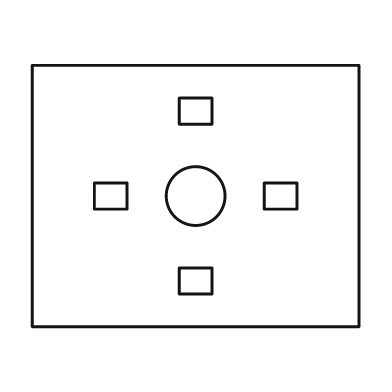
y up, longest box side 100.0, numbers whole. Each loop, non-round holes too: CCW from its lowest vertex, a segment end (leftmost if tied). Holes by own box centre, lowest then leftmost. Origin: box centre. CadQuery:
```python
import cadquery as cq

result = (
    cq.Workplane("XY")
    .moveTo(-50.0, -40.0)
    .lineTo(50.0, -40.0)
    .lineTo(50.0, 40.0)
    .lineTo(-50.0, 40.0)
    .close()
    .moveTo(-5.0, -30.0)
    .lineTo(5.0, -30.0)
    .lineTo(5.0, -22.0)
    .lineTo(-5.0, -22.0)
    .close()
    .moveTo(-31.0, -4.0)
    .lineTo(-21.0, -4.0)
    .lineTo(-21.0, 4.0)
    .lineTo(-31.0, 4.0)
    .close()
    .moveTo(0.0, 0.0)
    .circle(9.0)
    .moveTo(21.0, -4.0)
    .lineTo(31.0, -4.0)
    .lineTo(31.0, 4.0)
    .lineTo(21.0, 4.0)
    .close()
    .moveTo(-5.0, 22.0)
    .lineTo(5.0, 22.0)
    .lineTo(5.0, 30.0)
    .lineTo(-5.0, 30.0)
    .close()
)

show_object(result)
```